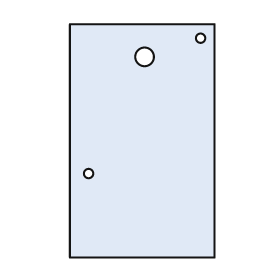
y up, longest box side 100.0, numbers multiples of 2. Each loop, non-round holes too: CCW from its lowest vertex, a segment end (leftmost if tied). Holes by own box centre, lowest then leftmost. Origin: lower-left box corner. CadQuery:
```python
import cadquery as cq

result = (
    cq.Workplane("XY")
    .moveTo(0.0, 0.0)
    .lineTo(62.0, 0.0)
    .lineTo(62.0, 100.0)
    .lineTo(0.0, 100.0)
    .close()
    .moveTo(8.0, 36.0)
    .circle(2.0)
    .moveTo(32.0, 86.0)
    .circle(4.0)
    .moveTo(56.0, 94.0)
    .circle(2.0)
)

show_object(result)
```